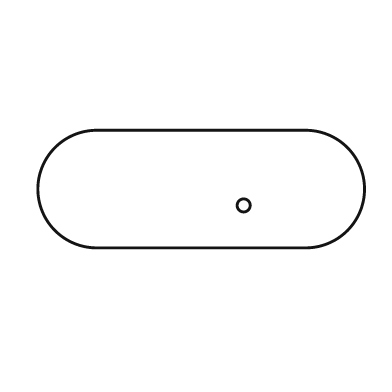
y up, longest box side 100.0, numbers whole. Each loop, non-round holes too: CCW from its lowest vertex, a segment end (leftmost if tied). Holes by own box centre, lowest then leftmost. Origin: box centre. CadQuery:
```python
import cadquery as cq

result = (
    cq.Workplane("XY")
    .moveTo(-32.0, -18.0)
    .lineTo(32.0, -18.0)
    .threePointArc((50.0, 0.0), (32.0, 18.0))
    .lineTo(-32.0, 18.0)
    .threePointArc((-50.0, 0.0), (-32.0, -18.0))
    .close()
    .moveTo(13.0, -5.0)
    .circle(2.0)
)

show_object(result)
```